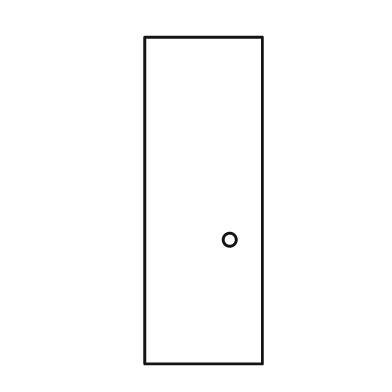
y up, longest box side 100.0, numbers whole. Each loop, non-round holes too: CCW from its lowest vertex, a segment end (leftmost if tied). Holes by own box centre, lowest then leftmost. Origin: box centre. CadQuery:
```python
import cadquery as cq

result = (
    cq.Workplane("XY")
    .moveTo(-18.0, -50.0)
    .lineTo(18.0, -50.0)
    .lineTo(18.0, 50.0)
    .lineTo(-18.0, 50.0)
    .close()
    .moveTo(8.0, -12.0)
    .circle(2.0)
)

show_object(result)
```